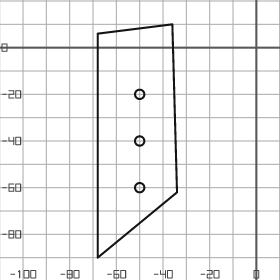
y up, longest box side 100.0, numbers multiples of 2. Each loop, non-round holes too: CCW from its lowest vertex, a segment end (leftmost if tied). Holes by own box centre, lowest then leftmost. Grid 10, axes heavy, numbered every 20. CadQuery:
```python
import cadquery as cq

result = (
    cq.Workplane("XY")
    .moveTo(-68.0, -90.0)
    .lineTo(-34.0, -62.0)
    .lineTo(-36.0, 10.0)
    .lineTo(-68.0, 6.0)
    .close()
    .moveTo(-50.0, -60.0)
    .circle(2.0)
    .moveTo(-50.0, -40.0)
    .circle(2.0)
    .moveTo(-50.0, -20.0)
    .circle(2.0)
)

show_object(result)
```